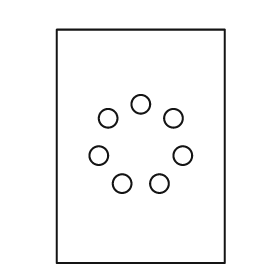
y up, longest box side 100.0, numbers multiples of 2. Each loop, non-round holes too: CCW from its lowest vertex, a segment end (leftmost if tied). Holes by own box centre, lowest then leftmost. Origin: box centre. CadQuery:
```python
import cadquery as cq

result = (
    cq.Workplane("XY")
    .moveTo(-36.0, -50.0)
    .lineTo(36.0, -50.0)
    .lineTo(36.0, 50.0)
    .lineTo(-36.0, 50.0)
    .close()
    .moveTo(-8.0, -16.0)
    .circle(4.0)
    .moveTo(8.0, -16.0)
    .circle(4.0)
    .moveTo(-18.0, -4.0)
    .circle(4.0)
    .moveTo(18.0, -4.0)
    .circle(4.0)
    .moveTo(-14.0, 12.0)
    .circle(4.0)
    .moveTo(14.0, 12.0)
    .circle(4.0)
    .moveTo(0.0, 18.0)
    .circle(4.0)
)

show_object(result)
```